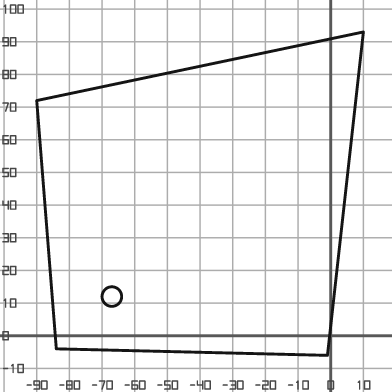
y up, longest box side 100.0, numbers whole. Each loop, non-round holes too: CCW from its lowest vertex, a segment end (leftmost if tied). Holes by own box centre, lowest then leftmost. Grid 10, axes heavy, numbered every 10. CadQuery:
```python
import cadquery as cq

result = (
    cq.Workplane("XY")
    .moveTo(-1.0, -6.0)
    .lineTo(10.0, 93.0)
    .lineTo(-90.0, 72.0)
    .lineTo(-84.0, -4.0)
    .close()
    .moveTo(-67.0, 12.0)
    .circle(3.0)
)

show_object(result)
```